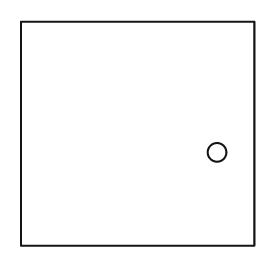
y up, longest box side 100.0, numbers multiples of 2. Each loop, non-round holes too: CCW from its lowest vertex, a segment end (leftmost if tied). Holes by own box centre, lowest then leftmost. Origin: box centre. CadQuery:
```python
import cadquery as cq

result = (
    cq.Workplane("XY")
    .moveTo(-50.0, -48.0)
    .lineTo(50.0, -48.0)
    .lineTo(50.0, 48.0)
    .lineTo(-50.0, 48.0)
    .close()
    .moveTo(34.0, -8.0)
    .circle(4.0)
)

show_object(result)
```